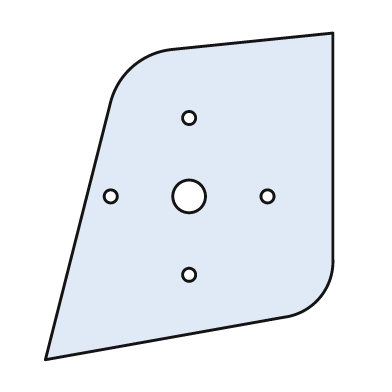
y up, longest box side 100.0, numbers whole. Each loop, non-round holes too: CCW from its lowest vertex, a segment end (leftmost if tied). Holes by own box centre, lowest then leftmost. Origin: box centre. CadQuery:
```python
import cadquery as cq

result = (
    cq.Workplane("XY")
    .moveTo(-44.0, -50.0)
    .lineTo(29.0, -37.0)
    .threePointArc((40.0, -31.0), (44.0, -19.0))
    .lineTo(44.0, 50.0)
    .lineTo(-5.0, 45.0)
    .threePointArc((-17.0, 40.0), (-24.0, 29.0))
    .close()
    .moveTo(0.0, -24.0)
    .circle(2.0)
    .moveTo(-24.0, 0.0)
    .circle(2.0)
    .moveTo(0.0, 0.0)
    .circle(5.0)
    .moveTo(24.0, 0.0)
    .circle(2.0)
    .moveTo(0.0, 24.0)
    .circle(2.0)
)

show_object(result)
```